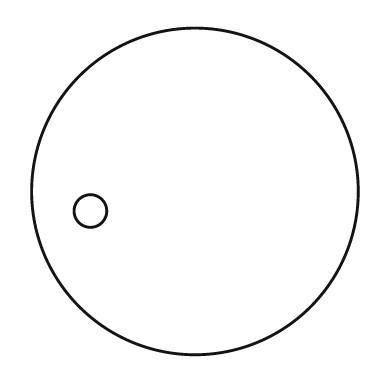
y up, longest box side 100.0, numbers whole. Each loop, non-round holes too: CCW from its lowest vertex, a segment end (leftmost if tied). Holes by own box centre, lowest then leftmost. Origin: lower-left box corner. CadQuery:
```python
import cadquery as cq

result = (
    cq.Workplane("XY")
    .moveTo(50.0, 50.0)
    .circle(50.0)
    .moveTo(18.0, 44.0)
    .circle(5.0)
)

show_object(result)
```